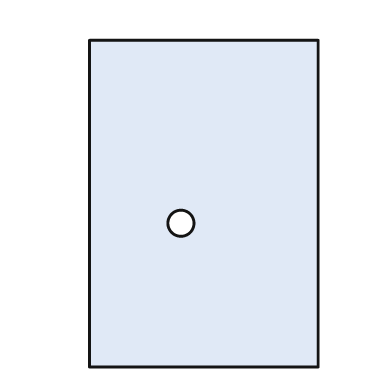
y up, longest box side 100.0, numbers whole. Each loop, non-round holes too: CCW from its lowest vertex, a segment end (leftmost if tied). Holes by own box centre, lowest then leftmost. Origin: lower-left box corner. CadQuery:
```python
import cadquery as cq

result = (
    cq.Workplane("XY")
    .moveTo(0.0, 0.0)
    .lineTo(70.0, 0.0)
    .lineTo(70.0, 100.0)
    .lineTo(0.0, 100.0)
    .close()
    .moveTo(28.0, 44.0)
    .circle(4.0)
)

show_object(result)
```